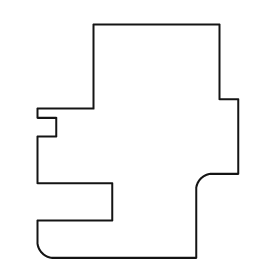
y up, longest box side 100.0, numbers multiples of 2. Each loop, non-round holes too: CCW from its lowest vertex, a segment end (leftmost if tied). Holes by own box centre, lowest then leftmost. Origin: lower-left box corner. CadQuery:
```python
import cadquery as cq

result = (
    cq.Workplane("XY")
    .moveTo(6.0, 0.0)
    .lineTo(68.0, 0.0)
    .lineTo(68.0, 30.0)
    .threePointArc((70.0, 34.0), (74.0, 36.0))
    .lineTo(86.0, 36.0)
    .lineTo(86.0, 68.0)
    .lineTo(78.0, 68.0)
    .lineTo(78.0, 100.0)
    .lineTo(24.0, 100.0)
    .lineTo(24.0, 64.0)
    .lineTo(0.0, 64.0)
    .lineTo(0.0, 60.0)
    .lineTo(8.0, 60.0)
    .lineTo(8.0, 52.0)
    .lineTo(0.0, 52.0)
    .lineTo(0.0, 32.0)
    .lineTo(32.0, 32.0)
    .lineTo(32.0, 16.0)
    .lineTo(0.0, 16.0)
    .lineTo(0.0, 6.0)
    .threePointArc((2.0, 2.0), (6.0, 0.0))
    .close()
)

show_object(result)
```